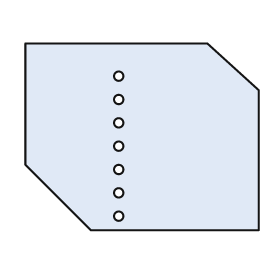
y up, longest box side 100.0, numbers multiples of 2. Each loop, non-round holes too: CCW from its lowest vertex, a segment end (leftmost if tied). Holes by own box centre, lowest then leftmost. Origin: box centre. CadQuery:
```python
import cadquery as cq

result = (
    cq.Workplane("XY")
    .moveTo(-22.0, -40.0)
    .lineTo(50.0, -40.0)
    .lineTo(50.0, 20.0)
    .lineTo(28.0, 40.0)
    .lineTo(-50.0, 40.0)
    .lineTo(-50.0, -12.0)
    .close()
    .moveTo(-10.0, -34.0)
    .circle(2.0)
    .moveTo(-10.0, -24.0)
    .circle(2.0)
    .moveTo(-10.0, -14.0)
    .circle(2.0)
    .moveTo(-10.0, -4.0)
    .circle(2.0)
    .moveTo(-10.0, 6.0)
    .circle(2.0)
    .moveTo(-10.0, 16.0)
    .circle(2.0)
    .moveTo(-10.0, 26.0)
    .circle(2.0)
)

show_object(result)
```